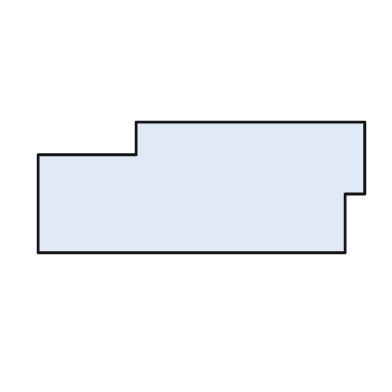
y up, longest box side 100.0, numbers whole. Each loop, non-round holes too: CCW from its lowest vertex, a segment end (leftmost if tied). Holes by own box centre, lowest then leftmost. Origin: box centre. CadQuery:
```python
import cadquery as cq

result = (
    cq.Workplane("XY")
    .moveTo(-50.0, -20.0)
    .lineTo(44.0, -20.0)
    .lineTo(44.0, -2.0)
    .lineTo(50.0, -2.0)
    .lineTo(50.0, 20.0)
    .lineTo(-20.0, 20.0)
    .lineTo(-20.0, 10.0)
    .lineTo(-50.0, 10.0)
    .close()
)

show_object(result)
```